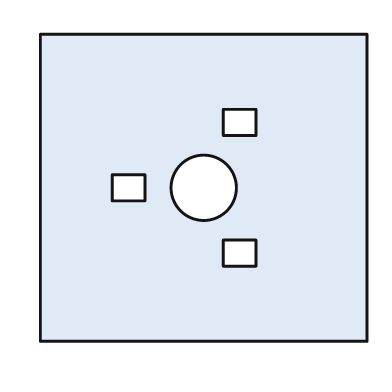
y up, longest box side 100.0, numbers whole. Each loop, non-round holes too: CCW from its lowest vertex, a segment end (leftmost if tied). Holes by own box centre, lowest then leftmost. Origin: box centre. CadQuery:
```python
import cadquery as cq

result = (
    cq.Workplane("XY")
    .moveTo(-50.0, -47.0)
    .lineTo(50.0, -47.0)
    .lineTo(50.0, 47.0)
    .lineTo(-50.0, 47.0)
    .close()
    .moveTo(6.0, -24.0)
    .lineTo(16.0, -24.0)
    .lineTo(16.0, -16.0)
    .lineTo(6.0, -16.0)
    .close()
    .moveTo(-28.0, -4.0)
    .lineTo(-18.0, -4.0)
    .lineTo(-18.0, 4.0)
    .lineTo(-28.0, 4.0)
    .close()
    .moveTo(0.0, 0.0)
    .circle(10.0)
    .moveTo(6.0, 16.0)
    .lineTo(16.0, 16.0)
    .lineTo(16.0, 24.0)
    .lineTo(6.0, 24.0)
    .close()
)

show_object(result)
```